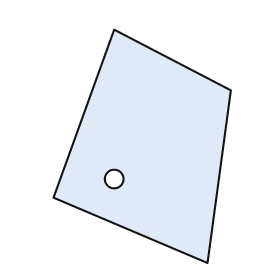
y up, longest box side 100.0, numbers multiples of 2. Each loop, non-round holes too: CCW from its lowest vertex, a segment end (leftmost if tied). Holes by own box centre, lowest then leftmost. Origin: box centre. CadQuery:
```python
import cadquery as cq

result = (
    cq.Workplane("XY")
    .moveTo(28.0, -50.0)
    .lineTo(38.0, 24.0)
    .lineTo(-12.0, 50.0)
    .lineTo(-38.0, -22.0)
    .close()
    .moveTo(-12.0, -14.0)
    .circle(4.0)
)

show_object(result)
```